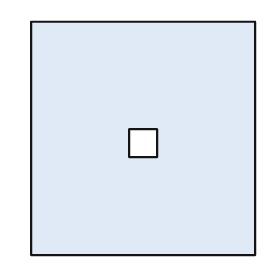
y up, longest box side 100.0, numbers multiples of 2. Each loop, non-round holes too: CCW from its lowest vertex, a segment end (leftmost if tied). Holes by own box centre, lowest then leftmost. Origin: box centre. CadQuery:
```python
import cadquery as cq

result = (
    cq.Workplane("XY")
    .moveTo(-48.0, -50.0)
    .lineTo(48.0, -50.0)
    .lineTo(48.0, 50.0)
    .lineTo(-48.0, 50.0)
    .close()
    .moveTo(-6.0, -8.0)
    .lineTo(6.0, -8.0)
    .lineTo(6.0, 4.0)
    .lineTo(-6.0, 4.0)
    .close()
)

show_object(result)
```